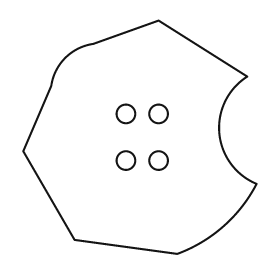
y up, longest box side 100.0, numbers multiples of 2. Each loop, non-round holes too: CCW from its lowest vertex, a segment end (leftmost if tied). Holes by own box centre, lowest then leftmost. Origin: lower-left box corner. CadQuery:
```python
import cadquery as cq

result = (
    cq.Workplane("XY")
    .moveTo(66.0, 0.0)
    .threePointArc((86.0, 12.0), (100.0, 30.0))
    .threePointArc((84.0, 52.0), (96.0, 76.0))
    .lineTo(58.0, 100.0)
    .lineTo(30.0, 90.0)
    .threePointArc((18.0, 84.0), (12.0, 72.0))
    .lineTo(0.0, 44.0)
    .lineTo(22.0, 6.0)
    .close()
    .moveTo(44.0, 40.0)
    .circle(4.0)
    .moveTo(58.0, 40.0)
    .circle(4.0)
    .moveTo(44.0, 60.0)
    .circle(4.0)
    .moveTo(58.0, 60.0)
    .circle(4.0)
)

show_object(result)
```